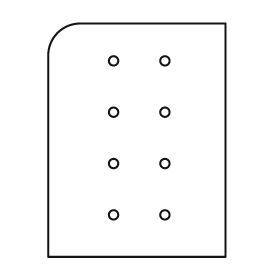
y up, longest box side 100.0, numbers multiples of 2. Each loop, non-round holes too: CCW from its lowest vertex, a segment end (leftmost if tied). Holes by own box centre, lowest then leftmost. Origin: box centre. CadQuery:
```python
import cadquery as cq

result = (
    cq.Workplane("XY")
    .moveTo(-38.0, -50.0)
    .lineTo(38.0, -50.0)
    .lineTo(38.0, 50.0)
    .lineTo(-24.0, 50.0)
    .threePointArc((-34.0, 46.0), (-38.0, 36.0))
    .close()
    .moveTo(-10.0, -32.0)
    .circle(2.0)
    .moveTo(12.0, -32.0)
    .circle(2.0)
    .moveTo(-10.0, -10.0)
    .circle(2.0)
    .moveTo(12.0, -10.0)
    .circle(2.0)
    .moveTo(-10.0, 12.0)
    .circle(2.0)
    .moveTo(12.0, 12.0)
    .circle(2.0)
    .moveTo(-10.0, 34.0)
    .circle(2.0)
    .moveTo(12.0, 34.0)
    .circle(2.0)
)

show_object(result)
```